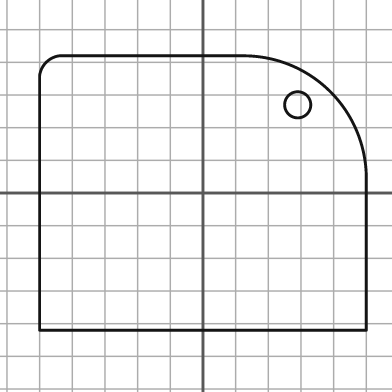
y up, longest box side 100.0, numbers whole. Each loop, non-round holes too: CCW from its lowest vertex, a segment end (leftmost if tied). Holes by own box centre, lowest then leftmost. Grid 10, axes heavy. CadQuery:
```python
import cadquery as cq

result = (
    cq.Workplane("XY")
    .moveTo(-50.0, -42.0)
    .lineTo(50.0, -42.0)
    .lineTo(50.0, 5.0)
    .threePointArc((39.0, 31.0), (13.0, 42.0))
    .lineTo(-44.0, 42.0)
    .threePointArc((-48.0, 40.0), (-50.0, 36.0))
    .close()
    .moveTo(29.0, 27.0)
    .circle(4.0)
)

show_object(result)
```